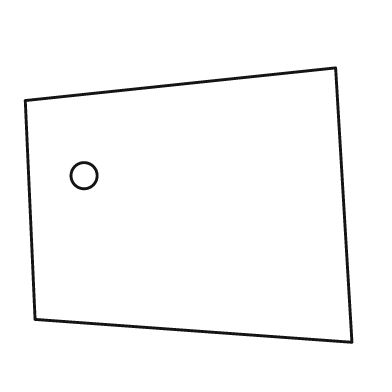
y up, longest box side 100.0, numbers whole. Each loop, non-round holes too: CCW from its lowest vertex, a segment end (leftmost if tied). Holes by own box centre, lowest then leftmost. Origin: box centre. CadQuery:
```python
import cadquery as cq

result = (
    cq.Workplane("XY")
    .moveTo(50.0, -42.0)
    .lineTo(45.0, 42.0)
    .lineTo(-50.0, 32.0)
    .lineTo(-47.0, -35.0)
    .close()
    .moveTo(-32.0, 9.0)
    .circle(4.0)
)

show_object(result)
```